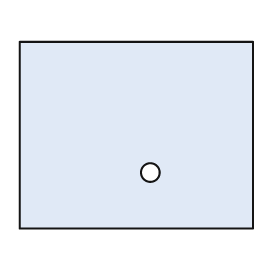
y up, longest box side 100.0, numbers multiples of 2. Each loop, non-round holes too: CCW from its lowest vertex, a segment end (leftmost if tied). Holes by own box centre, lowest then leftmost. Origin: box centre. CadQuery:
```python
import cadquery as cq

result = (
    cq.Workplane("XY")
    .moveTo(-50.0, -40.0)
    .lineTo(50.0, -40.0)
    .lineTo(50.0, 40.0)
    .lineTo(-50.0, 40.0)
    .close()
    .moveTo(6.0, -16.0)
    .circle(4.0)
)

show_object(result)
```